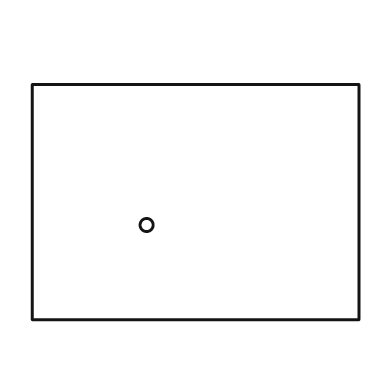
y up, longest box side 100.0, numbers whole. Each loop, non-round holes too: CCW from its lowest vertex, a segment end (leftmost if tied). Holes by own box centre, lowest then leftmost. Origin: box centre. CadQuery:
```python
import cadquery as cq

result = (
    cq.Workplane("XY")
    .moveTo(-50.0, -36.0)
    .lineTo(50.0, -36.0)
    .lineTo(50.0, 36.0)
    .lineTo(-50.0, 36.0)
    .close()
    .moveTo(-15.0, -7.0)
    .circle(2.0)
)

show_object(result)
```